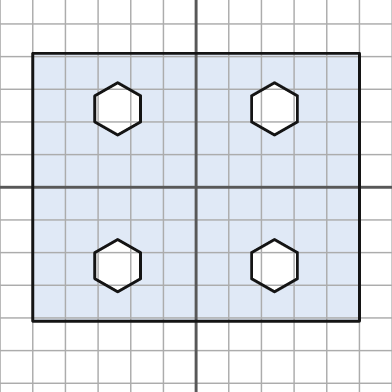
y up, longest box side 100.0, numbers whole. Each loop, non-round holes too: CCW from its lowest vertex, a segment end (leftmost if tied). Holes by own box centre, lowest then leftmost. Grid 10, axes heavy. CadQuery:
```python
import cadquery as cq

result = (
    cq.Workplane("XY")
    .moveTo(-50.0, -41.0)
    .lineTo(50.0, -41.0)
    .lineTo(50.0, 41.0)
    .lineTo(-50.0, 41.0)
    .close()
    .moveTo(-24.0, -32.0)
    .lineTo(-17.0, -28.0)
    .lineTo(-17.0, -20.0)
    .lineTo(-24.0, -16.0)
    .lineTo(-31.0, -20.0)
    .lineTo(-31.0, -28.0)
    .close()
    .moveTo(24.0, -32.0)
    .lineTo(31.0, -28.0)
    .lineTo(31.0, -20.0)
    .lineTo(24.0, -16.0)
    .lineTo(17.0, -20.0)
    .lineTo(17.0, -28.0)
    .close()
    .moveTo(-24.0, 16.0)
    .lineTo(-17.0, 20.0)
    .lineTo(-17.0, 28.0)
    .lineTo(-24.0, 32.0)
    .lineTo(-31.0, 28.0)
    .lineTo(-31.0, 20.0)
    .close()
    .moveTo(24.0, 16.0)
    .lineTo(31.0, 20.0)
    .lineTo(31.0, 28.0)
    .lineTo(24.0, 32.0)
    .lineTo(17.0, 28.0)
    .lineTo(17.0, 20.0)
    .close()
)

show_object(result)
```